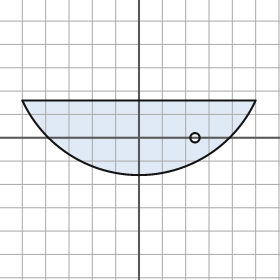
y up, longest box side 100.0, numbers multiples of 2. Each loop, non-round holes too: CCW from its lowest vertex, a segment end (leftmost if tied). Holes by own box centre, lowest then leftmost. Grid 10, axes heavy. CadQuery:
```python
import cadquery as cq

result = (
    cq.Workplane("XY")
    .moveTo(-50.0, 16.0)
    .threePointArc((0.0, -16.0), (50.0, 16.0))
    .close()
    .moveTo(24.0, 0.0)
    .circle(2.0)
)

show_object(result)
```